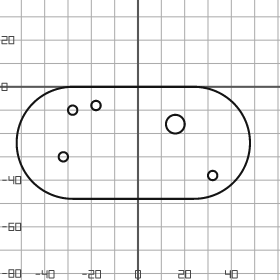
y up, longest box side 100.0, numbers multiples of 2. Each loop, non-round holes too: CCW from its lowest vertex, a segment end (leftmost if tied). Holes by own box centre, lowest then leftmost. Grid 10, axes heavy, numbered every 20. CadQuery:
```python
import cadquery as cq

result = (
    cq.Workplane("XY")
    .moveTo(-28.0, -48.0)
    .lineTo(24.0, -48.0)
    .threePointArc((48.0, -24.0), (24.0, 0.0))
    .lineTo(-28.0, 0.0)
    .threePointArc((-52.0, -24.0), (-28.0, -48.0))
    .close()
    .moveTo(32.0, -38.0)
    .circle(2.0)
    .moveTo(-32.0, -30.0)
    .circle(2.0)
    .moveTo(16.0, -16.0)
    .circle(4.0)
    .moveTo(-28.0, -10.0)
    .circle(2.0)
    .moveTo(-18.0, -8.0)
    .circle(2.0)
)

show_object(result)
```